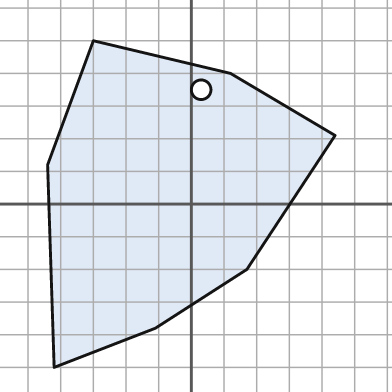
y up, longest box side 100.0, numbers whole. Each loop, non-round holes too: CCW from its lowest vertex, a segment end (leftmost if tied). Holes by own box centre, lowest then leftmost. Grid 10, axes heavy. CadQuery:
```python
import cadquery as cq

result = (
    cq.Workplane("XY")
    .moveTo(-42.0, -50.0)
    .lineTo(-11.0, -38.0)
    .lineTo(17.0, -20.0)
    .lineTo(44.0, 21.0)
    .lineTo(12.0, 40.0)
    .lineTo(-30.0, 50.0)
    .lineTo(-44.0, 12.0)
    .close()
    .moveTo(3.0, 35.0)
    .circle(3.0)
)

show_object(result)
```